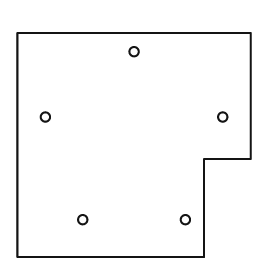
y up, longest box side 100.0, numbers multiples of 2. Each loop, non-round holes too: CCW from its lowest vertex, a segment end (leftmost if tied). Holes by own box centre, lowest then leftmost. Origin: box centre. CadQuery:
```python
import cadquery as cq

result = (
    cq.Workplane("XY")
    .moveTo(-50.0, -48.0)
    .lineTo(30.0, -48.0)
    .lineTo(30.0, -6.0)
    .lineTo(50.0, -6.0)
    .lineTo(50.0, 48.0)
    .lineTo(-50.0, 48.0)
    .close()
    .moveTo(-22.0, -32.0)
    .circle(2.0)
    .moveTo(22.0, -32.0)
    .circle(2.0)
    .moveTo(-38.0, 12.0)
    .circle(2.0)
    .moveTo(38.0, 12.0)
    .circle(2.0)
    .moveTo(0.0, 40.0)
    .circle(2.0)
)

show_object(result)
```